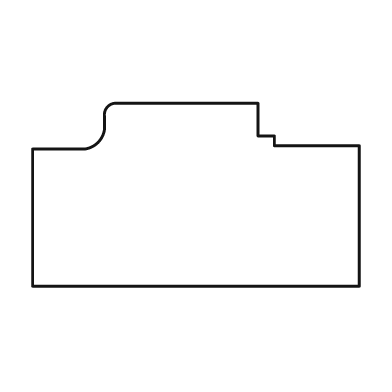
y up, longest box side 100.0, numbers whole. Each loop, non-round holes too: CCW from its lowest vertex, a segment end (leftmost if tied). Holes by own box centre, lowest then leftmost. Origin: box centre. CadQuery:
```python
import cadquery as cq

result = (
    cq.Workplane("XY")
    .moveTo(-50.0, -28.0)
    .lineTo(50.0, -28.0)
    .lineTo(50.0, 15.0)
    .lineTo(24.0, 15.0)
    .lineTo(24.0, 18.0)
    .lineTo(19.0, 18.0)
    .lineTo(19.0, 28.0)
    .lineTo(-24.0, 28.0)
    .threePointArc((-27.0, 27.0), (-28.0, 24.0))
    .lineTo(-28.0, 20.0)
    .threePointArc((-30.0, 16.0), (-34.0, 14.0))
    .lineTo(-50.0, 14.0)
    .close()
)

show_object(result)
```